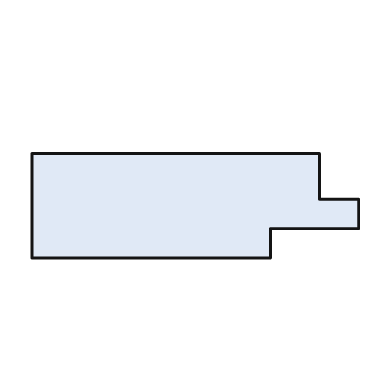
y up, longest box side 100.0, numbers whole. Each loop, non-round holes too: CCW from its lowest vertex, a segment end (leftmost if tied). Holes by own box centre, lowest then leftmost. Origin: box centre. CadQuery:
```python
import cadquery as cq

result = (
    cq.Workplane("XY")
    .moveTo(-50.0, -16.0)
    .lineTo(23.0, -16.0)
    .lineTo(23.0, -7.0)
    .lineTo(50.0, -7.0)
    .lineTo(50.0, 2.0)
    .lineTo(38.0, 2.0)
    .lineTo(38.0, 16.0)
    .lineTo(-50.0, 16.0)
    .close()
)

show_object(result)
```